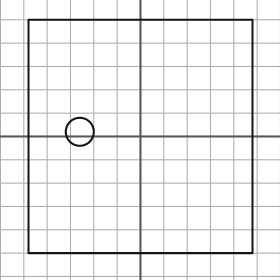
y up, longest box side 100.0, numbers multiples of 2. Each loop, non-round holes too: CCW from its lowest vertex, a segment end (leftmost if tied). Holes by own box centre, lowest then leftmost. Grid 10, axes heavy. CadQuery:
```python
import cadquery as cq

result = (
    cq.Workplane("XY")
    .moveTo(-48.0, -50.0)
    .lineTo(48.0, -50.0)
    .lineTo(48.0, 50.0)
    .lineTo(-48.0, 50.0)
    .close()
    .moveTo(-26.0, 2.0)
    .circle(6.0)
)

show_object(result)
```